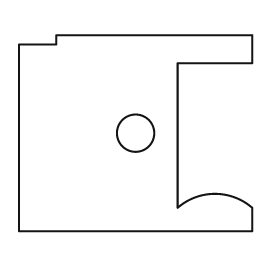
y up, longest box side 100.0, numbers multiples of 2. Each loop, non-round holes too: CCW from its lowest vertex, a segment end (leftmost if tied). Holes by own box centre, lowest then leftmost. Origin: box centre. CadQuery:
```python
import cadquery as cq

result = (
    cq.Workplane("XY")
    .moveTo(-50.0, -42.0)
    .lineTo(50.0, -42.0)
    .lineTo(50.0, -32.0)
    .threePointArc((34.0, -26.0), (18.0, -32.0))
    .lineTo(18.0, 30.0)
    .lineTo(50.0, 30.0)
    .lineTo(50.0, 42.0)
    .lineTo(-34.0, 42.0)
    .lineTo(-34.0, 38.0)
    .lineTo(-50.0, 38.0)
    .close()
    .moveTo(0.0, 0.0)
    .circle(8.0)
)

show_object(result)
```